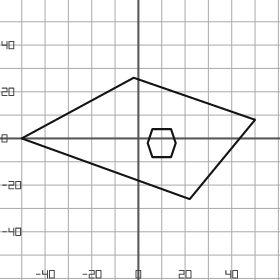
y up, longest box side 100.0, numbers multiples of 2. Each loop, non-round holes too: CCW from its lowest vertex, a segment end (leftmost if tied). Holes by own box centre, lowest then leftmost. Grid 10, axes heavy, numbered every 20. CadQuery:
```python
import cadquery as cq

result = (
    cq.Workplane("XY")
    .moveTo(22.0, -26.0)
    .lineTo(50.0, 8.0)
    .lineTo(-2.0, 26.0)
    .lineTo(-50.0, 0.0)
    .close()
    .moveTo(6.0, -8.0)
    .lineTo(14.0, -8.0)
    .lineTo(16.0, -2.0)
    .lineTo(14.0, 4.0)
    .lineTo(6.0, 4.0)
    .lineTo(4.0, -2.0)
    .close()
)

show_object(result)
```